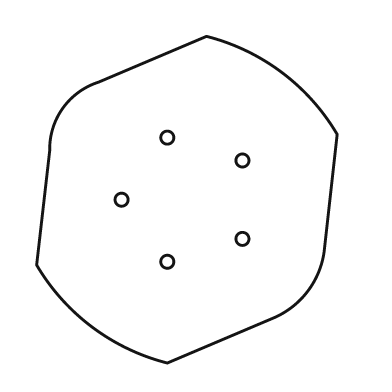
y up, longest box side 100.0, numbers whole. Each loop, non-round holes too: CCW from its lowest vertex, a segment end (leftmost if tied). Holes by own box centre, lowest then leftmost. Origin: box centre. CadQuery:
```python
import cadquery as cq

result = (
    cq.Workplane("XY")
    .moveTo(-6.0, -50.0)
    .lineTo(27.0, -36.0)
    .threePointArc((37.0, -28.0), (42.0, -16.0))
    .lineTo(46.0, 20.0)
    .threePointArc((29.0, 39.0), (6.0, 50.0))
    .lineTo(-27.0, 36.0)
    .threePointArc((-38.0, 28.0), (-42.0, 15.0))
    .lineTo(-46.0, -20.0)
    .threePointArc((-29.0, -39.0), (-6.0, -50.0))
    .close()
    .moveTo(-6.0, -19.0)
    .circle(2.0)
    .moveTo(17.0, -12.0)
    .circle(2.0)
    .moveTo(-20.0, 0.0)
    .circle(2.0)
    .moveTo(17.0, 12.0)
    .circle(2.0)
    .moveTo(-6.0, 19.0)
    .circle(2.0)
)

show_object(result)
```